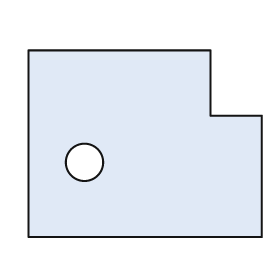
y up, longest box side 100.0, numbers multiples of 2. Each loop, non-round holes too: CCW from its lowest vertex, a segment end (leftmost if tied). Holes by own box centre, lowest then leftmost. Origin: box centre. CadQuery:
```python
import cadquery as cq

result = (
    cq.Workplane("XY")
    .moveTo(-50.0, -40.0)
    .lineTo(50.0, -40.0)
    .lineTo(50.0, 12.0)
    .lineTo(28.0, 12.0)
    .lineTo(28.0, 40.0)
    .lineTo(-50.0, 40.0)
    .close()
    .moveTo(-26.0, -8.0)
    .circle(8.0)
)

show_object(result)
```